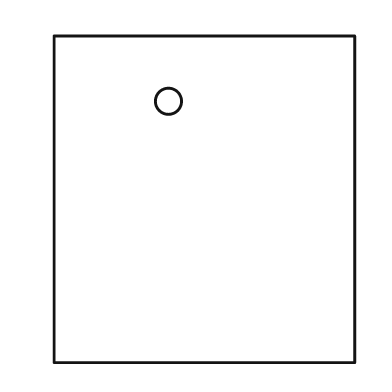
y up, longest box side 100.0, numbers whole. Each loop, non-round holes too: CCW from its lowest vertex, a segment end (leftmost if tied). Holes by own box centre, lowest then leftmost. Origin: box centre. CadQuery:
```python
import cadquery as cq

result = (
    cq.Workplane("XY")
    .moveTo(-46.0, -50.0)
    .lineTo(46.0, -50.0)
    .lineTo(46.0, 50.0)
    .lineTo(-46.0, 50.0)
    .close()
    .moveTo(-11.0, 30.0)
    .circle(4.0)
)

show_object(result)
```